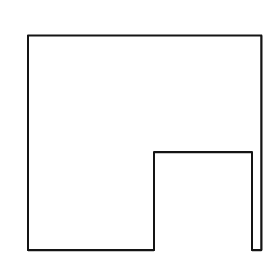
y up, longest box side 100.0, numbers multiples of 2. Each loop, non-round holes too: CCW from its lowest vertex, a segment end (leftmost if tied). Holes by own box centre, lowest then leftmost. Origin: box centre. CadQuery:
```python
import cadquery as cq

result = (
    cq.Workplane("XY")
    .moveTo(-50.0, -46.0)
    .lineTo(4.0, -46.0)
    .lineTo(4.0, -4.0)
    .lineTo(46.0, -4.0)
    .lineTo(46.0, -46.0)
    .lineTo(50.0, -46.0)
    .lineTo(50.0, 46.0)
    .lineTo(-50.0, 46.0)
    .close()
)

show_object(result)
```